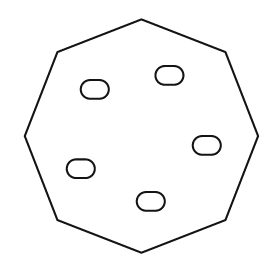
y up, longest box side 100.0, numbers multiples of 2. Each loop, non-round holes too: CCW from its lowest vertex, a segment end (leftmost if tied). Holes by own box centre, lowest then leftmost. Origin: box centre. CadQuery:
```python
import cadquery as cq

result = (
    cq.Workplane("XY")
    .moveTo(0.0, -50.0)
    .lineTo(36.0, -36.0)
    .lineTo(50.0, 0.0)
    .lineTo(36.0, 36.0)
    .lineTo(0.0, 50.0)
    .lineTo(-36.0, 36.0)
    .lineTo(-50.0, 0.0)
    .lineTo(-36.0, -36.0)
    .close()
    .moveTo(2.0, -32.0)
    .lineTo(6.0, -32.0)
    .threePointArc((10.0, -28.0), (6.0, -24.0))
    .lineTo(2.0, -24.0)
    .threePointArc((-2.0, -28.0), (2.0, -32.0))
    .close()
    .moveTo(-28.0, -18.0)
    .lineTo(-24.0, -18.0)
    .threePointArc((-20.0, -14.0), (-24.0, -10.0))
    .lineTo(-28.0, -10.0)
    .threePointArc((-32.0, -14.0), (-28.0, -18.0))
    .close()
    .moveTo(26.0, -8.0)
    .lineTo(30.0, -8.0)
    .threePointArc((34.0, -4.0), (30.0, 0.0))
    .lineTo(26.0, 0.0)
    .threePointArc((22.0, -4.0), (26.0, -8.0))
    .close()
    .moveTo(-22.0, 16.0)
    .lineTo(-18.0, 16.0)
    .threePointArc((-14.0, 20.0), (-18.0, 24.0))
    .lineTo(-22.0, 24.0)
    .threePointArc((-26.0, 20.0), (-22.0, 16.0))
    .close()
    .moveTo(10.0, 22.0)
    .lineTo(14.0, 22.0)
    .threePointArc((18.0, 26.0), (14.0, 30.0))
    .lineTo(10.0, 30.0)
    .threePointArc((6.0, 26.0), (10.0, 22.0))
    .close()
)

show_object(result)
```